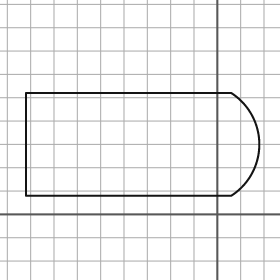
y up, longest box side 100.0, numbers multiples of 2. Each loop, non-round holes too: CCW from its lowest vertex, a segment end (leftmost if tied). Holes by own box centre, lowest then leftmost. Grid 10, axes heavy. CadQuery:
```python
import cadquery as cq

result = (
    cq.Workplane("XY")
    .moveTo(-82.0, 8.0)
    .lineTo(6.0, 8.0)
    .threePointArc((18.0, 30.0), (6.0, 52.0))
    .lineTo(-82.0, 52.0)
    .close()
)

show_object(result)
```